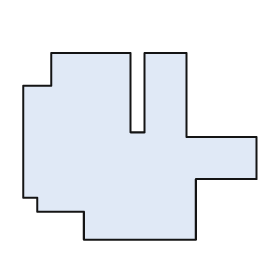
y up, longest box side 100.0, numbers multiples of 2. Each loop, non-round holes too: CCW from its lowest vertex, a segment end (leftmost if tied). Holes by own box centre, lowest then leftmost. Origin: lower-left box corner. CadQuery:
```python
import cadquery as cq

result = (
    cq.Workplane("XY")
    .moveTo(26.0, 0.0)
    .lineTo(74.0, 0.0)
    .lineTo(74.0, 26.0)
    .lineTo(100.0, 26.0)
    .lineTo(100.0, 44.0)
    .lineTo(70.0, 44.0)
    .lineTo(70.0, 80.0)
    .lineTo(52.0, 80.0)
    .lineTo(52.0, 46.0)
    .lineTo(46.0, 46.0)
    .lineTo(46.0, 80.0)
    .lineTo(12.0, 80.0)
    .lineTo(12.0, 66.0)
    .lineTo(0.0, 66.0)
    .lineTo(0.0, 18.0)
    .lineTo(6.0, 18.0)
    .lineTo(6.0, 12.0)
    .lineTo(26.0, 12.0)
    .close()
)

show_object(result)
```